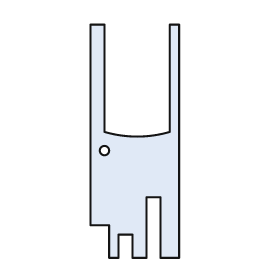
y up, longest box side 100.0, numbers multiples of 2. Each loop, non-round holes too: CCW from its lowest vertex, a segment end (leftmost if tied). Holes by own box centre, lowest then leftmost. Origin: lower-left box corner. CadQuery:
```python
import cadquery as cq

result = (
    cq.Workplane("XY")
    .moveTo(8.0, 0.0)
    .lineTo(12.0, 0.0)
    .lineTo(12.0, 10.0)
    .lineTo(18.0, 10.0)
    .lineTo(18.0, 0.0)
    .lineTo(24.0, 0.0)
    .lineTo(24.0, 26.0)
    .lineTo(30.0, 26.0)
    .lineTo(30.0, 0.0)
    .lineTo(38.0, 0.0)
    .lineTo(38.0, 100.0)
    .lineTo(34.0, 100.0)
    .lineTo(34.0, 54.0)
    .threePointArc((20.0, 52.0), (6.0, 54.0))
    .lineTo(6.0, 100.0)
    .lineTo(0.0, 100.0)
    .lineTo(0.0, 14.0)
    .lineTo(8.0, 14.0)
    .close()
    .moveTo(6.0, 46.0)
    .circle(2.0)
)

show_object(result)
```